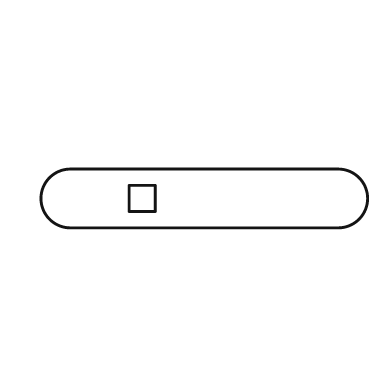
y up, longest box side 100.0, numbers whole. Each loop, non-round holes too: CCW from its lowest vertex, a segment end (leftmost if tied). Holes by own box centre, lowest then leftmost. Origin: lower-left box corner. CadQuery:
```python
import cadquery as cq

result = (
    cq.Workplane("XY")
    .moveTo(9.0, 0.0)
    .lineTo(91.0, 0.0)
    .threePointArc((100.0, 9.0), (91.0, 18.0))
    .lineTo(9.0, 18.0)
    .threePointArc((0.0, 9.0), (9.0, 0.0))
    .close()
    .moveTo(27.0, 5.0)
    .lineTo(35.0, 5.0)
    .lineTo(35.0, 13.0)
    .lineTo(27.0, 13.0)
    .close()
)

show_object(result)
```